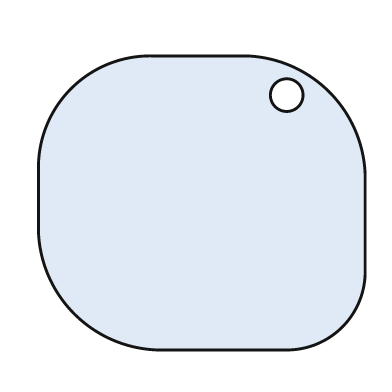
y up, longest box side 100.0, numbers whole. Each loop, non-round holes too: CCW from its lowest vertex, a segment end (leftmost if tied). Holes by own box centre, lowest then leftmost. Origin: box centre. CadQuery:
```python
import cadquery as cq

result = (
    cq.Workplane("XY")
    .moveTo(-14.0, -45.0)
    .lineTo(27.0, -45.0)
    .threePointArc((43.0, -38.0), (50.0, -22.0))
    .lineTo(50.0, 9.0)
    .threePointArc((39.0, 34.0), (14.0, 45.0))
    .lineTo(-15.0, 45.0)
    .threePointArc((-40.0, 35.0), (-50.0, 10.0))
    .lineTo(-50.0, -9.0)
    .threePointArc((-39.0, -34.0), (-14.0, -45.0))
    .close()
    .moveTo(26.0, 33.0)
    .circle(5.0)
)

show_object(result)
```